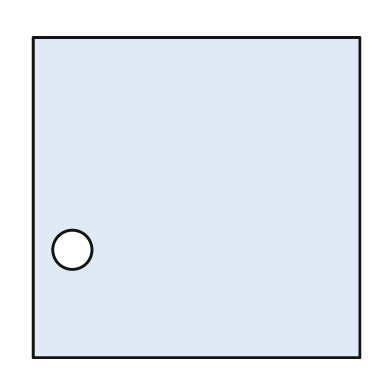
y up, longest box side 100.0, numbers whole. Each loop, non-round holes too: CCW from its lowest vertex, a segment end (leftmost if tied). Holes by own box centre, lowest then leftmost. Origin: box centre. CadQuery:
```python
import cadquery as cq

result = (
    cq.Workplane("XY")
    .moveTo(-50.0, -49.0)
    .lineTo(50.0, -49.0)
    .lineTo(50.0, 49.0)
    .lineTo(-50.0, 49.0)
    .close()
    .moveTo(-38.0, -16.0)
    .circle(6.0)
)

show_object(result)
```